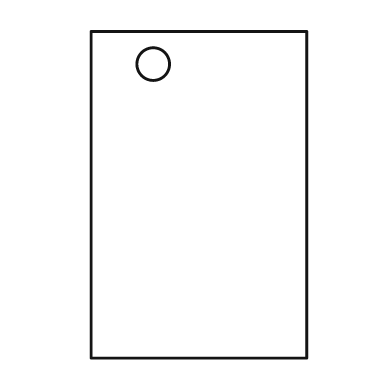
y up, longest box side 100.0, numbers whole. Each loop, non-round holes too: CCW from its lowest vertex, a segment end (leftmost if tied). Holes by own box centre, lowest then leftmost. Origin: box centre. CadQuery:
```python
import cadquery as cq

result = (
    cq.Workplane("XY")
    .moveTo(-33.0, -50.0)
    .lineTo(33.0, -50.0)
    .lineTo(33.0, 50.0)
    .lineTo(-33.0, 50.0)
    .close()
    .moveTo(-14.0, 40.0)
    .circle(5.0)
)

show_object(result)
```